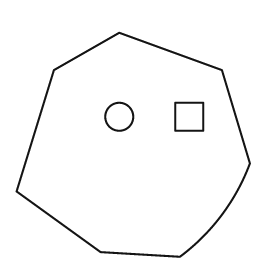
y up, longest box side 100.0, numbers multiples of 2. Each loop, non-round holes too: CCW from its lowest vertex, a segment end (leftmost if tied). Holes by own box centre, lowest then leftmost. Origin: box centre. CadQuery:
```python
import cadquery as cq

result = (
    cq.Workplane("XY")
    .moveTo(20.0, -48.0)
    .threePointArc((38.0, -30.0), (50.0, -8.0))
    .lineTo(38.0, 32.0)
    .lineTo(-6.0, 48.0)
    .lineTo(-34.0, 32.0)
    .lineTo(-50.0, -20.0)
    .lineTo(-14.0, -46.0)
    .close()
    .moveTo(-6.0, 12.0)
    .circle(6.0)
    .moveTo(18.0, 6.0)
    .lineTo(30.0, 6.0)
    .lineTo(30.0, 18.0)
    .lineTo(18.0, 18.0)
    .close()
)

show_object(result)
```